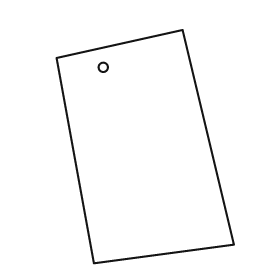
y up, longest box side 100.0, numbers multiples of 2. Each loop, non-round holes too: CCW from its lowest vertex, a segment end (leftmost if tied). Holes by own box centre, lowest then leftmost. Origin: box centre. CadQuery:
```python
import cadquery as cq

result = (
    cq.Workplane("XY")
    .moveTo(-22.0, -50.0)
    .lineTo(38.0, -42.0)
    .lineTo(16.0, 50.0)
    .lineTo(-38.0, 38.0)
    .close()
    .moveTo(-18.0, 34.0)
    .circle(2.0)
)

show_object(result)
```